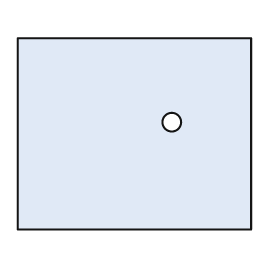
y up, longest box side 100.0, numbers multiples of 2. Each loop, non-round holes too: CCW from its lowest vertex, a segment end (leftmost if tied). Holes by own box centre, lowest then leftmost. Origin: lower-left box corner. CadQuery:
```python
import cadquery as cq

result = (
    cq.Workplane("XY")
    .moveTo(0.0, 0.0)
    .lineTo(100.0, 0.0)
    .lineTo(100.0, 82.0)
    .lineTo(0.0, 82.0)
    .close()
    .moveTo(66.0, 46.0)
    .circle(4.0)
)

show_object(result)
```